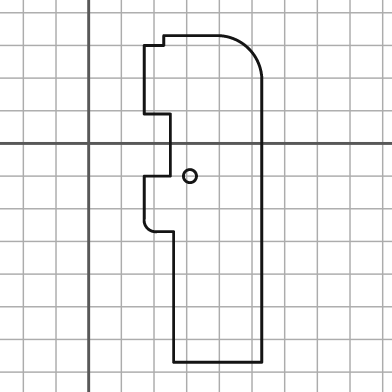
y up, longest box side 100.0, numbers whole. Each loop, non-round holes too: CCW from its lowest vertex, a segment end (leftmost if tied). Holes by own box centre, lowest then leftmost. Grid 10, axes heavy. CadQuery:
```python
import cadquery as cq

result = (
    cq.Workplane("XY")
    .moveTo(26.0, -67.0)
    .lineTo(53.0, -67.0)
    .lineTo(53.0, 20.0)
    .threePointArc((49.0, 29.0), (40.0, 33.0))
    .lineTo(23.0, 33.0)
    .lineTo(23.0, 30.0)
    .lineTo(17.0, 30.0)
    .lineTo(17.0, 9.0)
    .lineTo(25.0, 9.0)
    .lineTo(25.0, -10.0)
    .lineTo(17.0, -10.0)
    .lineTo(17.0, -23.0)
    .threePointArc((18.0, -26.0), (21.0, -27.0))
    .lineTo(26.0, -27.0)
    .close()
    .moveTo(31.0, -10.0)
    .circle(2.0)
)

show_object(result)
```